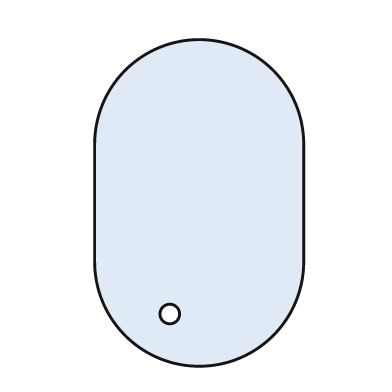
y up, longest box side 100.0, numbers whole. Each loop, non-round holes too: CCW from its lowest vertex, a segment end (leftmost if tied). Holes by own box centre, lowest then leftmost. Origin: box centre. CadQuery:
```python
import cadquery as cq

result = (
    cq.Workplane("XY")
    .moveTo(-32.0, -18.0)
    .threePointArc((0.0, -50.0), (32.0, -18.0))
    .lineTo(32.0, 18.0)
    .threePointArc((0.0, 50.0), (-32.0, 18.0))
    .close()
    .moveTo(-9.0, -34.0)
    .circle(3.0)
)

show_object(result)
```